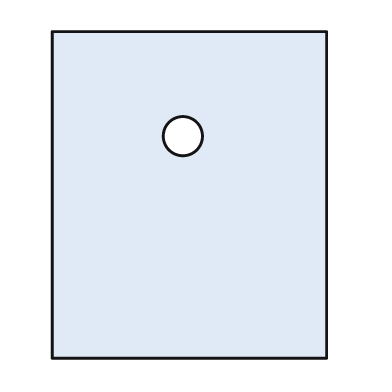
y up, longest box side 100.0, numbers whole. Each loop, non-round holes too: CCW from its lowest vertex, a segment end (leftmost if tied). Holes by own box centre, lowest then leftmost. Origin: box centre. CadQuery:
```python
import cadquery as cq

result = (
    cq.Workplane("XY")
    .moveTo(-42.0, -50.0)
    .lineTo(42.0, -50.0)
    .lineTo(42.0, 50.0)
    .lineTo(-42.0, 50.0)
    .close()
    .moveTo(-2.0, 18.0)
    .circle(6.0)
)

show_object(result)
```